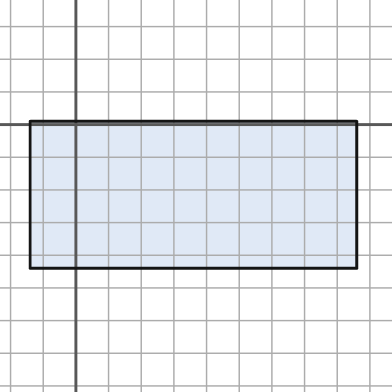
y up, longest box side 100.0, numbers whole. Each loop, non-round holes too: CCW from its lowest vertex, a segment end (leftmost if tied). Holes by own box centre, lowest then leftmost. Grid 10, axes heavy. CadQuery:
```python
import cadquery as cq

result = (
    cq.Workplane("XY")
    .moveTo(-14.0, -44.0)
    .lineTo(86.0, -44.0)
    .lineTo(86.0, 1.0)
    .lineTo(-14.0, 1.0)
    .close()
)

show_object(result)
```